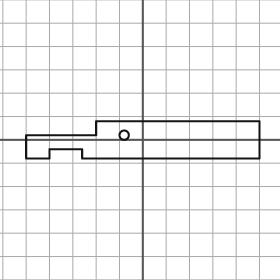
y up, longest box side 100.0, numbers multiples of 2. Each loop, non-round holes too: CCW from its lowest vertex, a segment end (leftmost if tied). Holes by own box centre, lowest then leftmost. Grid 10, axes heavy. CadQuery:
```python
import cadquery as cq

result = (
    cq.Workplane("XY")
    .moveTo(-50.0, -8.0)
    .lineTo(-40.0, -8.0)
    .lineTo(-40.0, -4.0)
    .lineTo(-26.0, -4.0)
    .lineTo(-26.0, -8.0)
    .lineTo(50.0, -8.0)
    .lineTo(50.0, 8.0)
    .lineTo(-20.0, 8.0)
    .lineTo(-20.0, 2.0)
    .lineTo(-50.0, 2.0)
    .close()
    .moveTo(-8.0, 2.0)
    .circle(2.0)
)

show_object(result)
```